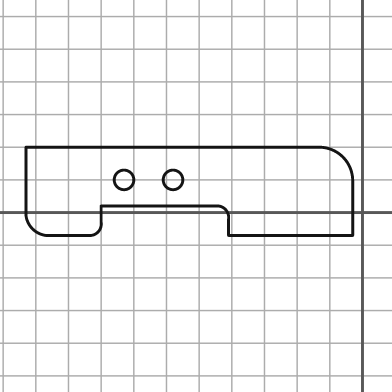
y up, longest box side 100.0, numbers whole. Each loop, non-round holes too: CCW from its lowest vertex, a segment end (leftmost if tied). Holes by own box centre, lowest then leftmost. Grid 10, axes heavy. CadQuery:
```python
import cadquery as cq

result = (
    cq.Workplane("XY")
    .moveTo(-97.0, -7.0)
    .lineTo(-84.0, -7.0)
    .threePointArc((-81.0, -6.0), (-80.0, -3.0))
    .lineTo(-80.0, 2.0)
    .lineTo(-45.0, 2.0)
    .threePointArc((-42.0, 1.0), (-41.0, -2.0))
    .lineTo(-41.0, -7.0)
    .lineTo(-3.0, -7.0)
    .lineTo(-3.0, 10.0)
    .threePointArc((-6.0, 17.0), (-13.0, 20.0))
    .lineTo(-103.0, 20.0)
    .lineTo(-103.0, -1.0)
    .threePointArc((-101.0, -5.0), (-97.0, -7.0))
    .close()
    .moveTo(-73.0, 10.0)
    .circle(3.0)
    .moveTo(-58.0, 10.0)
    .circle(3.0)
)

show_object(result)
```